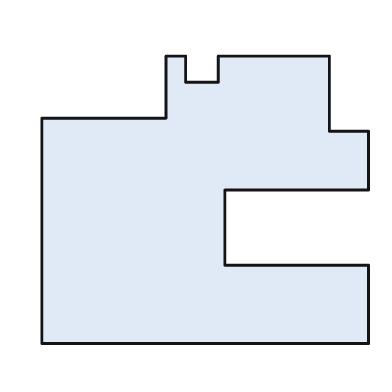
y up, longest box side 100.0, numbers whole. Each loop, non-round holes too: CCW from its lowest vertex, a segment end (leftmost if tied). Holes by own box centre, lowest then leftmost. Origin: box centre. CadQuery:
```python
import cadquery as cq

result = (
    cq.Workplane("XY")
    .moveTo(-50.0, -44.0)
    .lineTo(50.0, -44.0)
    .lineTo(50.0, -20.0)
    .lineTo(6.0, -20.0)
    .lineTo(6.0, 3.0)
    .lineTo(50.0, 3.0)
    .lineTo(50.0, 21.0)
    .lineTo(38.0, 21.0)
    .lineTo(38.0, 44.0)
    .lineTo(4.0, 44.0)
    .lineTo(4.0, 36.0)
    .lineTo(-6.0, 36.0)
    .lineTo(-6.0, 44.0)
    .lineTo(-12.0, 44.0)
    .lineTo(-12.0, 25.0)
    .lineTo(-50.0, 25.0)
    .close()
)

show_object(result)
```